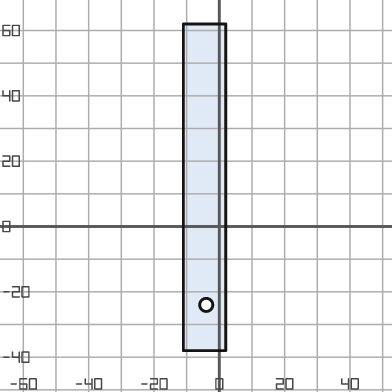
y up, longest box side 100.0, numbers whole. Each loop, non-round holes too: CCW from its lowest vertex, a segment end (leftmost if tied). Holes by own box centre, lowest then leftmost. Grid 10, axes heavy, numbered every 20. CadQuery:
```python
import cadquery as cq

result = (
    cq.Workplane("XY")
    .moveTo(-11.0, -38.0)
    .lineTo(2.0, -38.0)
    .lineTo(2.0, 62.0)
    .lineTo(-11.0, 62.0)
    .close()
    .moveTo(-4.0, -24.0)
    .circle(2.0)
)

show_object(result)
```